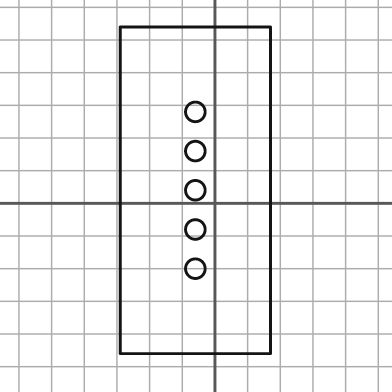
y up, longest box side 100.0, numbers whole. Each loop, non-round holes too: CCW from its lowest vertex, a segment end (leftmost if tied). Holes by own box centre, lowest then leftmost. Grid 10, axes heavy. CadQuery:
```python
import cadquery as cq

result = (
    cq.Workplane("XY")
    .moveTo(-29.0, -46.0)
    .lineTo(17.0, -46.0)
    .lineTo(17.0, 54.0)
    .lineTo(-29.0, 54.0)
    .close()
    .moveTo(-6.0, -20.0)
    .circle(3.0)
    .moveTo(-6.0, -8.0)
    .circle(3.0)
    .moveTo(-6.0, 4.0)
    .circle(3.0)
    .moveTo(-6.0, 16.0)
    .circle(3.0)
    .moveTo(-6.0, 28.0)
    .circle(3.0)
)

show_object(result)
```